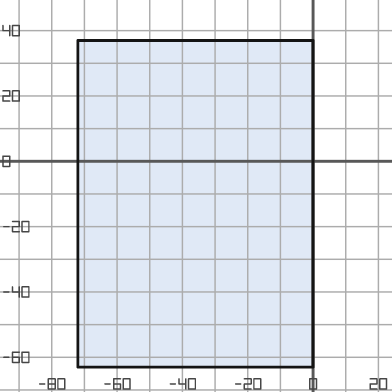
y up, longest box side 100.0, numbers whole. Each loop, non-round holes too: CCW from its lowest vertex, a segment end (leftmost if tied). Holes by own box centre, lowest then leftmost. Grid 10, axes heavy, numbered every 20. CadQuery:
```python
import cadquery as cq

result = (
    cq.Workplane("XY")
    .moveTo(-72.0, -63.0)
    .lineTo(0.0, -63.0)
    .lineTo(0.0, 37.0)
    .lineTo(-72.0, 37.0)
    .close()
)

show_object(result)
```